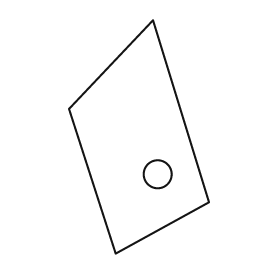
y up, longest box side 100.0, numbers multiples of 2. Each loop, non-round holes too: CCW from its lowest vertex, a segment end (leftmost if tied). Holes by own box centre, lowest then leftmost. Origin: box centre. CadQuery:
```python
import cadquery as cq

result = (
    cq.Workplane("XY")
    .moveTo(-10.0, -50.0)
    .lineTo(30.0, -28.0)
    .lineTo(6.0, 50.0)
    .lineTo(-30.0, 12.0)
    .close()
    .moveTo(8.0, -16.0)
    .circle(6.0)
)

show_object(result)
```